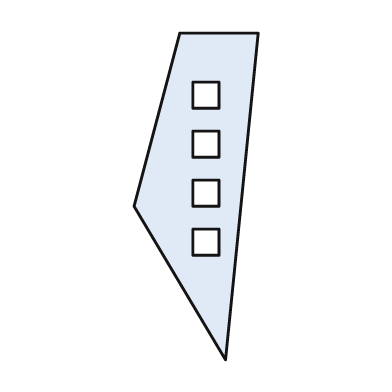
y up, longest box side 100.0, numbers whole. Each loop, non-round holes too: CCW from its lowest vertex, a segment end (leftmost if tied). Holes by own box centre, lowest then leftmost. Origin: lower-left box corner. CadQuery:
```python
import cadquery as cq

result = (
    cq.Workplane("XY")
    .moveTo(28.0, 0.0)
    .lineTo(38.0, 100.0)
    .lineTo(14.0, 100.0)
    .lineTo(0.0, 47.0)
    .close()
    .moveTo(18.0, 32.0)
    .lineTo(26.0, 32.0)
    .lineTo(26.0, 40.0)
    .lineTo(18.0, 40.0)
    .close()
    .moveTo(18.0, 47.0)
    .lineTo(26.0, 47.0)
    .lineTo(26.0, 55.0)
    .lineTo(18.0, 55.0)
    .close()
    .moveTo(18.0, 62.0)
    .lineTo(26.0, 62.0)
    .lineTo(26.0, 70.0)
    .lineTo(18.0, 70.0)
    .close()
    .moveTo(18.0, 77.0)
    .lineTo(26.0, 77.0)
    .lineTo(26.0, 85.0)
    .lineTo(18.0, 85.0)
    .close()
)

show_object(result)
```